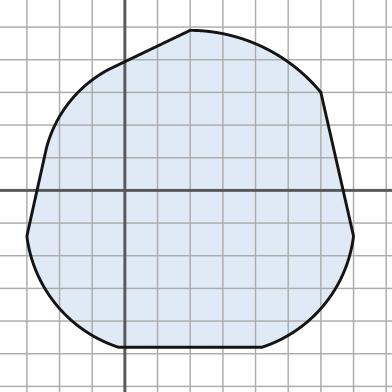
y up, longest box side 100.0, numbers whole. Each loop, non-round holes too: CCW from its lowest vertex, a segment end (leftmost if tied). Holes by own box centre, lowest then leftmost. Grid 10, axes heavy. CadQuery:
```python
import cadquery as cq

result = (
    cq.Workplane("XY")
    .moveTo(-2.0, -48.0)
    .lineTo(42.0, -48.0)
    .threePointArc((61.0, -35.0), (70.0, -14.0))
    .lineTo(60.0, 30.0)
    .threePointArc((42.0, 44.0), (20.0, 49.0))
    .lineTo(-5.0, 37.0)
    .threePointArc((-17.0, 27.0), (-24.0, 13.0))
    .lineTo(-30.0, -14.0)
    .threePointArc((-21.0, -35.0), (-2.0, -48.0))
    .close()
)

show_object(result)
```